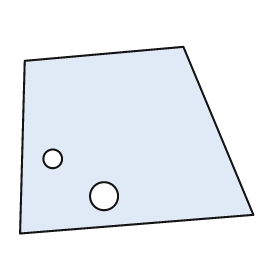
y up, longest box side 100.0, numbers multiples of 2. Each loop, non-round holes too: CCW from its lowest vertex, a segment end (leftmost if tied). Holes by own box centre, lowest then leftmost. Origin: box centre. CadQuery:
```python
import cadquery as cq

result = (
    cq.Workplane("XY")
    .moveTo(-50.0, -40.0)
    .lineTo(50.0, -32.0)
    .lineTo(20.0, 40.0)
    .lineTo(-48.0, 34.0)
    .close()
    .moveTo(-14.0, -24.0)
    .circle(6.0)
    .moveTo(-36.0, -8.0)
    .circle(4.0)
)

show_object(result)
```